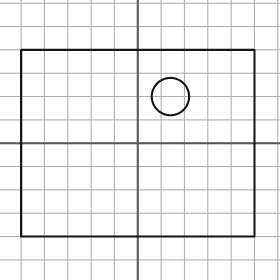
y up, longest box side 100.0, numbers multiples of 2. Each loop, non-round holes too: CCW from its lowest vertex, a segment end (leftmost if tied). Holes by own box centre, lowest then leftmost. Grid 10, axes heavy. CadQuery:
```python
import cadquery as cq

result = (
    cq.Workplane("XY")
    .moveTo(-50.0, -40.0)
    .lineTo(50.0, -40.0)
    .lineTo(50.0, 40.0)
    .lineTo(-50.0, 40.0)
    .close()
    .moveTo(14.0, 20.0)
    .circle(8.0)
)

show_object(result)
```